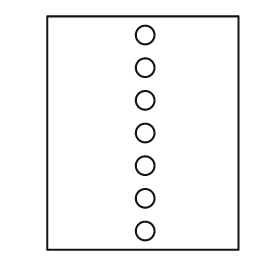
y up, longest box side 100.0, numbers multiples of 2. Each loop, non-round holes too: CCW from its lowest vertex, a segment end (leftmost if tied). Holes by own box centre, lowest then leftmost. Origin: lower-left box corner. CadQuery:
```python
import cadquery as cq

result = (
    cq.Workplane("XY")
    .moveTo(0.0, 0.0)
    .lineTo(82.0, 0.0)
    .lineTo(82.0, 100.0)
    .lineTo(0.0, 100.0)
    .close()
    .moveTo(42.0, 8.0)
    .circle(4.0)
    .moveTo(42.0, 22.0)
    .circle(4.0)
    .moveTo(42.0, 36.0)
    .circle(4.0)
    .moveTo(42.0, 50.0)
    .circle(4.0)
    .moveTo(42.0, 64.0)
    .circle(4.0)
    .moveTo(42.0, 78.0)
    .circle(4.0)
    .moveTo(42.0, 92.0)
    .circle(4.0)
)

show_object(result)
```